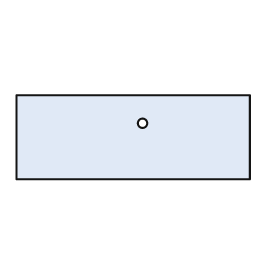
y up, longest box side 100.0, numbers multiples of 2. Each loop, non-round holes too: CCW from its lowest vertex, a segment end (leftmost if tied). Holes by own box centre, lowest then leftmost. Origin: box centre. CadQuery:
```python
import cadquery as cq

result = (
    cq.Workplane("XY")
    .moveTo(-50.0, -18.0)
    .lineTo(50.0, -18.0)
    .lineTo(50.0, 18.0)
    .lineTo(-50.0, 18.0)
    .close()
    .moveTo(4.0, 6.0)
    .circle(2.0)
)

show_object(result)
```